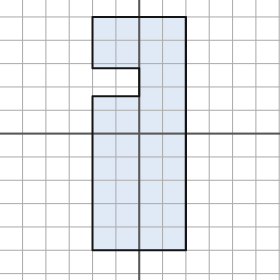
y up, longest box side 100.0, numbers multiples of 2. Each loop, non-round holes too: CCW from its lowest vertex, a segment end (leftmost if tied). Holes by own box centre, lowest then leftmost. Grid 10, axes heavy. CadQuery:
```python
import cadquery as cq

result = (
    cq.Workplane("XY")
    .moveTo(-20.0, -50.0)
    .lineTo(20.0, -50.0)
    .lineTo(20.0, 50.0)
    .lineTo(-20.0, 50.0)
    .lineTo(-20.0, 28.0)
    .lineTo(0.0, 28.0)
    .lineTo(0.0, 16.0)
    .lineTo(-20.0, 16.0)
    .close()
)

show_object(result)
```